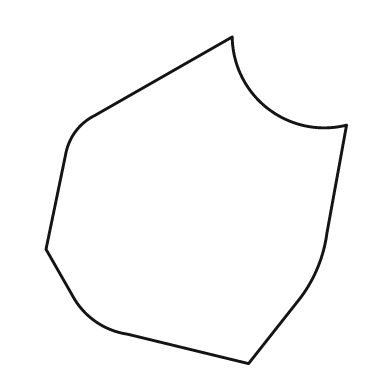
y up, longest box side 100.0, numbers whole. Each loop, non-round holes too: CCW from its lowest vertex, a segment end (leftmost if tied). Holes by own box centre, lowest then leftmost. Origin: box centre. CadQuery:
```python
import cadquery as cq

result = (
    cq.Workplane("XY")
    .moveTo(16.0, -50.0)
    .lineTo(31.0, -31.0)
    .threePointArc((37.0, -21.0), (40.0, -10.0))
    .lineTo(46.0, 23.0)
    .threePointArc((22.0, 28.0), (11.0, 50.0))
    .lineTo(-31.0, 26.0)
    .threePointArc((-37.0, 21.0), (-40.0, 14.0))
    .lineTo(-46.0, -15.0)
    .lineTo(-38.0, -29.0)
    .threePointArc((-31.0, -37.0), (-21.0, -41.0))
    .close()
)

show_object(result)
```